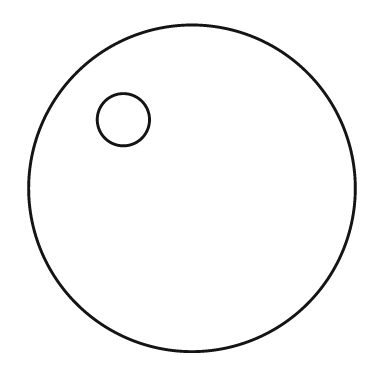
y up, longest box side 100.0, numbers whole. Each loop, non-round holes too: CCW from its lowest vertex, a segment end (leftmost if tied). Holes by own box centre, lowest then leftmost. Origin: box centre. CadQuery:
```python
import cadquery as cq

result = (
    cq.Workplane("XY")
    .moveTo(0.0, 0.0)
    .circle(50.0)
    .moveTo(-21.0, 21.0)
    .circle(8.0)
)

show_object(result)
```